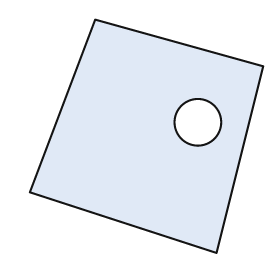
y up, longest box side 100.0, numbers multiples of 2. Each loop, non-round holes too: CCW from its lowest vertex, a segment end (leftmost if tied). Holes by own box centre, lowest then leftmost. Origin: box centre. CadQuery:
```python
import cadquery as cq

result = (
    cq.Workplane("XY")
    .moveTo(30.0, -50.0)
    .lineTo(50.0, 30.0)
    .lineTo(-22.0, 50.0)
    .lineTo(-50.0, -24.0)
    .close()
    .moveTo(22.0, 6.0)
    .circle(10.0)
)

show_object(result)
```